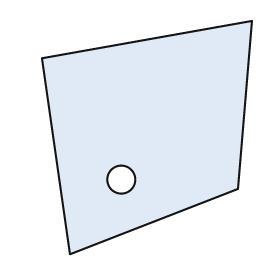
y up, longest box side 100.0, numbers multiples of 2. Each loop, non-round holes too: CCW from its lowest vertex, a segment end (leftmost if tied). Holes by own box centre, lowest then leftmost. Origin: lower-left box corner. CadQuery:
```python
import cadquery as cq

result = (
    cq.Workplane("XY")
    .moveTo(12.0, 0.0)
    .lineTo(84.0, 28.0)
    .lineTo(90.0, 100.0)
    .lineTo(0.0, 84.0)
    .close()
    .moveTo(34.0, 32.0)
    .circle(6.0)
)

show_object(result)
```